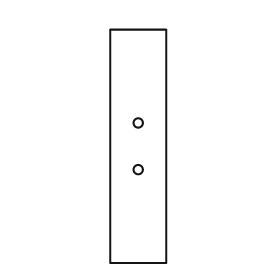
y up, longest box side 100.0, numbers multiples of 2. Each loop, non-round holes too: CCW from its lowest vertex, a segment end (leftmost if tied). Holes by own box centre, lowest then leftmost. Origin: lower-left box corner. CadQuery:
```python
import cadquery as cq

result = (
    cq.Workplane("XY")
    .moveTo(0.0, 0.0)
    .lineTo(24.0, 0.0)
    .lineTo(24.0, 100.0)
    .lineTo(0.0, 100.0)
    .close()
    .moveTo(12.0, 40.0)
    .circle(2.0)
    .moveTo(12.0, 60.0)
    .circle(2.0)
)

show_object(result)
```